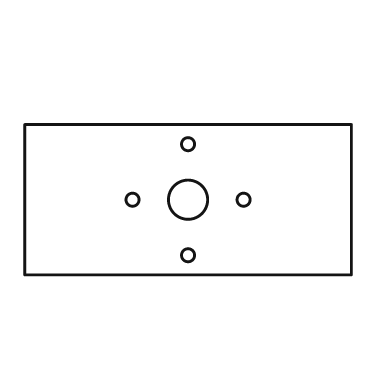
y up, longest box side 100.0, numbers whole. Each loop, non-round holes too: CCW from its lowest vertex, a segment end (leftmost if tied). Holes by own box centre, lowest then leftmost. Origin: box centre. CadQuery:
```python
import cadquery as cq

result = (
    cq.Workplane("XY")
    .moveTo(-50.0, -23.0)
    .lineTo(50.0, -23.0)
    .lineTo(50.0, 23.0)
    .lineTo(-50.0, 23.0)
    .close()
    .moveTo(0.0, -17.0)
    .circle(2.0)
    .moveTo(-17.0, 0.0)
    .circle(2.0)
    .moveTo(0.0, 0.0)
    .circle(6.0)
    .moveTo(17.0, 0.0)
    .circle(2.0)
    .moveTo(0.0, 17.0)
    .circle(2.0)
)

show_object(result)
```